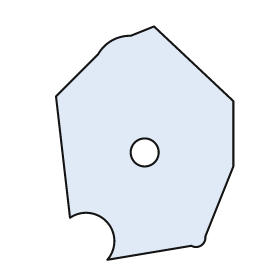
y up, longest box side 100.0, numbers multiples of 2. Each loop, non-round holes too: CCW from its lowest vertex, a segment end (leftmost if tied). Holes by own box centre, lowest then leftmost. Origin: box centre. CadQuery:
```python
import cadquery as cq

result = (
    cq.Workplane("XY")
    .moveTo(-16.0, -50.0)
    .lineTo(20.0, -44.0)
    .threePointArc((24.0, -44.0), (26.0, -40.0))
    .lineTo(38.0, -10.0)
    .lineTo(38.0, 18.0)
    .lineTo(4.0, 50.0)
    .lineTo(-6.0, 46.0)
    .threePointArc((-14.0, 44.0), (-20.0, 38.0))
    .lineTo(-38.0, 20.0)
    .lineTo(-32.0, -32.0)
    .threePointArc((-16.0, -34.0), (-16.0, -50.0))
    .close()
    .moveTo(0.0, -4.0)
    .circle(6.0)
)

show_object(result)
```